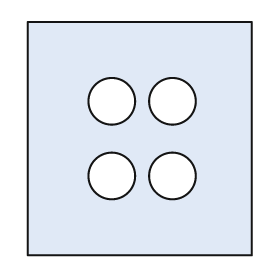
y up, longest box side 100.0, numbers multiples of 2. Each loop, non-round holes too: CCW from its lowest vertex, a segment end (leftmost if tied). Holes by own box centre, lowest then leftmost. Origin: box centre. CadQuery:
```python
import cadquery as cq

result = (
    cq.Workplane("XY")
    .moveTo(-48.0, -50.0)
    .lineTo(48.0, -50.0)
    .lineTo(48.0, 50.0)
    .lineTo(-48.0, 50.0)
    .close()
    .moveTo(-12.0, -16.0)
    .circle(10.0)
    .moveTo(14.0, -16.0)
    .circle(10.0)
    .moveTo(-12.0, 16.0)
    .circle(10.0)
    .moveTo(14.0, 16.0)
    .circle(10.0)
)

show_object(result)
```